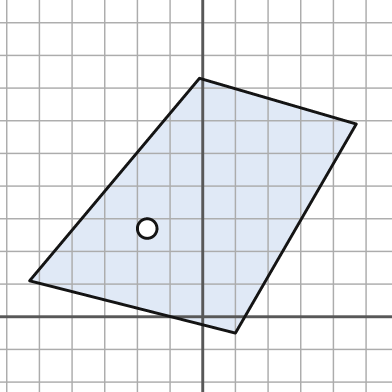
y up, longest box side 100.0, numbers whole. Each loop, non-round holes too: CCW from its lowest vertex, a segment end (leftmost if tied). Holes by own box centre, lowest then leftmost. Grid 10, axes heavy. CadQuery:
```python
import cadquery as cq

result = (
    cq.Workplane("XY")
    .moveTo(10.0, -5.0)
    .lineTo(47.0, 59.0)
    .lineTo(-1.0, 73.0)
    .lineTo(-53.0, 11.0)
    .close()
    .moveTo(-17.0, 27.0)
    .circle(3.0)
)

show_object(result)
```